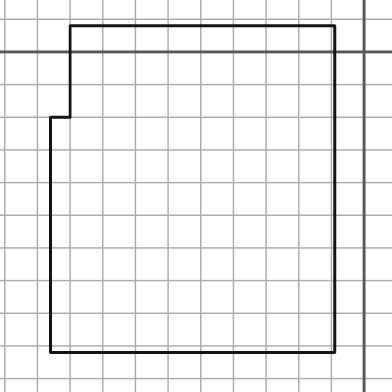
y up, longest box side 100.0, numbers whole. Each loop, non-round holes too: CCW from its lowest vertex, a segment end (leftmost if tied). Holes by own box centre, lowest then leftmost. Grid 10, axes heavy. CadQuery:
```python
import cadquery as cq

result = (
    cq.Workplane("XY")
    .moveTo(-96.0, -92.0)
    .lineTo(-9.0, -92.0)
    .lineTo(-9.0, 8.0)
    .lineTo(-90.0, 8.0)
    .lineTo(-90.0, -20.0)
    .lineTo(-96.0, -20.0)
    .close()
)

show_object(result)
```